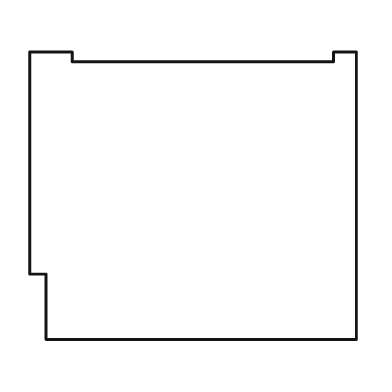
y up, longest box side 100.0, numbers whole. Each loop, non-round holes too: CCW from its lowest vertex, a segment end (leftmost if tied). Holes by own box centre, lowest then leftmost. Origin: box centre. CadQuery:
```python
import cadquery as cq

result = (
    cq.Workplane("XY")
    .moveTo(-45.0, -44.0)
    .lineTo(50.0, -44.0)
    .lineTo(50.0, 44.0)
    .lineTo(43.0, 44.0)
    .lineTo(43.0, 41.0)
    .lineTo(-37.0, 41.0)
    .lineTo(-37.0, 44.0)
    .lineTo(-50.0, 44.0)
    .lineTo(-50.0, -24.0)
    .lineTo(-45.0, -24.0)
    .close()
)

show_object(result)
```